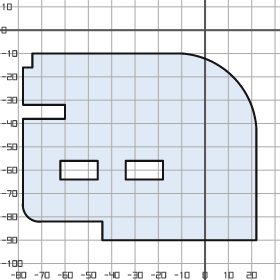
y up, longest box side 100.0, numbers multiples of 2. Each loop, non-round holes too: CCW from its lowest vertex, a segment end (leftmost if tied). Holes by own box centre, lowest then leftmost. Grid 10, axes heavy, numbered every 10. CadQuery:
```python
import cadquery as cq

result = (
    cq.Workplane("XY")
    .moveTo(-44.0, -90.0)
    .lineTo(22.0, -90.0)
    .lineTo(22.0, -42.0)
    .threePointArc((12.0, -20.0), (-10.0, -10.0))
    .lineTo(-74.0, -10.0)
    .lineTo(-74.0, -16.0)
    .lineTo(-78.0, -16.0)
    .lineTo(-78.0, -32.0)
    .lineTo(-60.0, -32.0)
    .lineTo(-60.0, -38.0)
    .lineTo(-78.0, -38.0)
    .lineTo(-78.0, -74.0)
    .threePointArc((-76.0, -80.0), (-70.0, -82.0))
    .lineTo(-44.0, -82.0)
    .close()
    .moveTo(-62.0, -64.0)
    .lineTo(-46.0, -64.0)
    .lineTo(-46.0, -56.0)
    .lineTo(-62.0, -56.0)
    .close()
    .moveTo(-34.0, -64.0)
    .lineTo(-18.0, -64.0)
    .lineTo(-18.0, -56.0)
    .lineTo(-34.0, -56.0)
    .close()
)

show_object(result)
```